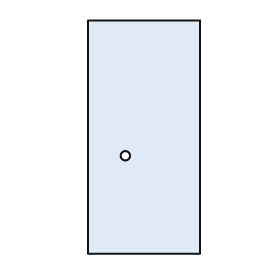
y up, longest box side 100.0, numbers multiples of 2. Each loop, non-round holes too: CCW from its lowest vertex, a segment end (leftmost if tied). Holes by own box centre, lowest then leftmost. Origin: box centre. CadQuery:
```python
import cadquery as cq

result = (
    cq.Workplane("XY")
    .moveTo(-24.0, -50.0)
    .lineTo(24.0, -50.0)
    .lineTo(24.0, 50.0)
    .lineTo(-24.0, 50.0)
    .close()
    .moveTo(-8.0, -8.0)
    .circle(2.0)
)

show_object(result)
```